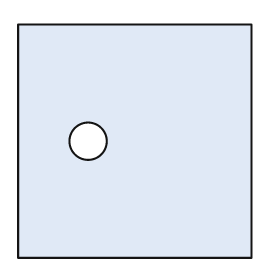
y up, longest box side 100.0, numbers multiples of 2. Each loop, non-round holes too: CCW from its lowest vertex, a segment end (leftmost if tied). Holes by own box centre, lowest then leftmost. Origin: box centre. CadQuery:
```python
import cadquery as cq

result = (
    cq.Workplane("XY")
    .moveTo(-50.0, -50.0)
    .lineTo(50.0, -50.0)
    .lineTo(50.0, 50.0)
    .lineTo(-50.0, 50.0)
    .close()
    .moveTo(-20.0, 0.0)
    .circle(8.0)
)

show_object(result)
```